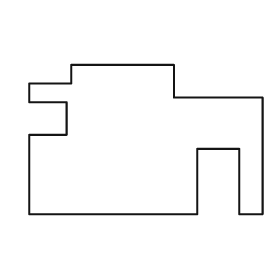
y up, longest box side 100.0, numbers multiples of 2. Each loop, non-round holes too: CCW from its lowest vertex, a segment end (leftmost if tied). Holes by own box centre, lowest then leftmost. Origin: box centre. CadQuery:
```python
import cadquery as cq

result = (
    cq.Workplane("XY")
    .moveTo(-50.0, -32.0)
    .lineTo(22.0, -32.0)
    .lineTo(22.0, -4.0)
    .lineTo(40.0, -4.0)
    .lineTo(40.0, -32.0)
    .lineTo(50.0, -32.0)
    .lineTo(50.0, 18.0)
    .lineTo(12.0, 18.0)
    .lineTo(12.0, 32.0)
    .lineTo(-32.0, 32.0)
    .lineTo(-32.0, 24.0)
    .lineTo(-50.0, 24.0)
    .lineTo(-50.0, 16.0)
    .lineTo(-34.0, 16.0)
    .lineTo(-34.0, 2.0)
    .lineTo(-50.0, 2.0)
    .close()
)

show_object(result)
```